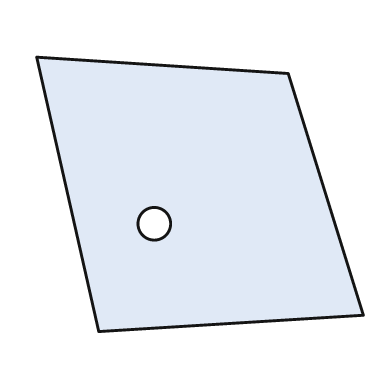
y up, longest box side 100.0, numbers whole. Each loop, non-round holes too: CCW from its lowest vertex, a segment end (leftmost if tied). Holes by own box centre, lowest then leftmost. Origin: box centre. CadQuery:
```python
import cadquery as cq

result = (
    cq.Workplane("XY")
    .moveTo(-31.0, -42.0)
    .lineTo(50.0, -37.0)
    .lineTo(27.0, 37.0)
    .lineTo(-50.0, 42.0)
    .close()
    .moveTo(-14.0, -9.0)
    .circle(5.0)
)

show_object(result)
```